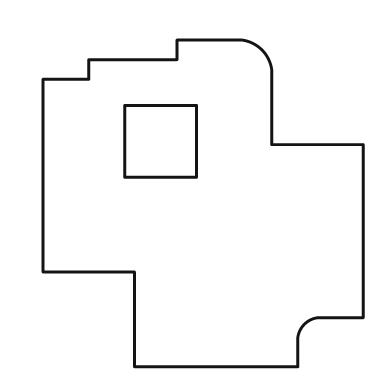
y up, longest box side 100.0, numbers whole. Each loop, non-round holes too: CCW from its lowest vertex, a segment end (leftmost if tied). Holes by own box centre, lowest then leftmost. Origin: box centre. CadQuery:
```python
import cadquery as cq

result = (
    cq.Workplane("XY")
    .moveTo(-21.0, -50.0)
    .lineTo(29.0, -50.0)
    .lineTo(29.0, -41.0)
    .threePointArc((31.0, -37.0), (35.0, -35.0))
    .lineTo(49.0, -35.0)
    .lineTo(49.0, 18.0)
    .lineTo(21.0, 18.0)
    .lineTo(21.0, 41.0)
    .threePointArc((18.0, 47.0), (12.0, 50.0))
    .lineTo(-8.0, 50.0)
    .lineTo(-8.0, 44.0)
    .lineTo(-35.0, 44.0)
    .lineTo(-35.0, 38.0)
    .lineTo(-49.0, 38.0)
    .lineTo(-49.0, -21.0)
    .lineTo(-21.0, -21.0)
    .close()
    .moveTo(-24.0, 8.0)
    .lineTo(-2.0, 8.0)
    .lineTo(-2.0, 30.0)
    .lineTo(-24.0, 30.0)
    .close()
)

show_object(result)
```